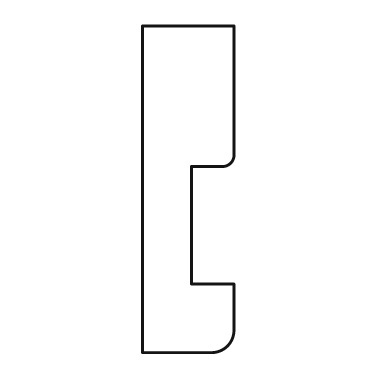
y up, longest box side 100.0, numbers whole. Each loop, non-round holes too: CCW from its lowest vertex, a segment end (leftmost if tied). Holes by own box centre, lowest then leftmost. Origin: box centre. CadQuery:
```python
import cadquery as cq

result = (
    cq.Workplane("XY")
    .moveTo(-14.0, -50.0)
    .lineTo(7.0, -50.0)
    .threePointArc((12.0, -48.0), (14.0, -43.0))
    .lineTo(14.0, -29.0)
    .lineTo(1.0, -29.0)
    .lineTo(1.0, 7.0)
    .lineTo(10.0, 7.0)
    .threePointArc((13.0, 8.0), (14.0, 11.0))
    .lineTo(14.0, 50.0)
    .lineTo(-14.0, 50.0)
    .close()
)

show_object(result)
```